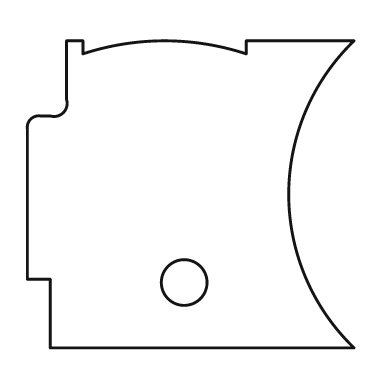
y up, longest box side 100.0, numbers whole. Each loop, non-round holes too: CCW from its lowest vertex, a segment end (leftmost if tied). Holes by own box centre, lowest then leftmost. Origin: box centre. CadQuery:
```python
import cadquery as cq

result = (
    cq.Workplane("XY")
    .moveTo(-43.0, -47.0)
    .lineTo(50.0, -47.0)
    .threePointArc((30.0, 0.0), (50.0, 47.0))
    .lineTo(17.0, 47.0)
    .lineTo(17.0, 43.0)
    .threePointArc((-8.0, 47.0), (-33.0, 43.0))
    .lineTo(-33.0, 47.0)
    .lineTo(-38.0, 47.0)
    .lineTo(-38.0, 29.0)
    .threePointArc((-39.0, 25.0), (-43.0, 24.0))
    .lineTo(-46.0, 24.0)
    .threePointArc((-49.0, 23.0), (-50.0, 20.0))
    .lineTo(-50.0, -26.0)
    .lineTo(-43.0, -26.0)
    .close()
    .moveTo(-2.0, -27.0)
    .circle(7.0)
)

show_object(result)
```